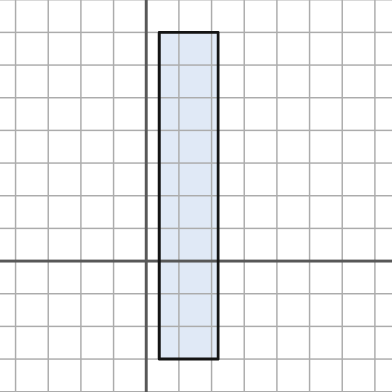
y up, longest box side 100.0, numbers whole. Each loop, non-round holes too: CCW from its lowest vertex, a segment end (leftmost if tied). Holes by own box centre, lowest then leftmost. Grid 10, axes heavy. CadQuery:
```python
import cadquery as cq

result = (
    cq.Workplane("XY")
    .moveTo(4.0, -30.0)
    .lineTo(22.0, -30.0)
    .lineTo(22.0, 70.0)
    .lineTo(4.0, 70.0)
    .close()
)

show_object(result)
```